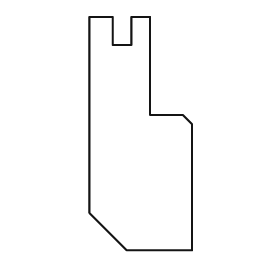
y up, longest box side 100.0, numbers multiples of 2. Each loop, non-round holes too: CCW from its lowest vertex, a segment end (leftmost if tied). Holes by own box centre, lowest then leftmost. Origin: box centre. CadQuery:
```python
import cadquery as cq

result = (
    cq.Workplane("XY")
    .moveTo(-6.0, -50.0)
    .lineTo(22.0, -50.0)
    .lineTo(22.0, 4.0)
    .lineTo(18.0, 8.0)
    .lineTo(4.0, 8.0)
    .lineTo(4.0, 50.0)
    .lineTo(-4.0, 50.0)
    .lineTo(-4.0, 38.0)
    .lineTo(-12.0, 38.0)
    .lineTo(-12.0, 50.0)
    .lineTo(-22.0, 50.0)
    .lineTo(-22.0, -34.0)
    .close()
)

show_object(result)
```